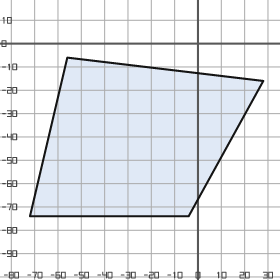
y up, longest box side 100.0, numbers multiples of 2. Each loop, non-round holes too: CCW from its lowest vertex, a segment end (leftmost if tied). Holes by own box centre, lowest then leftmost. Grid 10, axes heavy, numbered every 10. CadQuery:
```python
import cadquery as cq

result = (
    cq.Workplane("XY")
    .moveTo(-72.0, -74.0)
    .lineTo(-4.0, -74.0)
    .lineTo(28.0, -16.0)
    .lineTo(-56.0, -6.0)
    .close()
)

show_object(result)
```